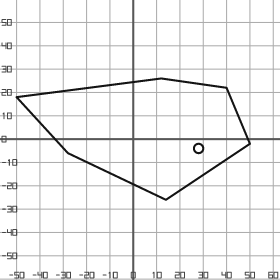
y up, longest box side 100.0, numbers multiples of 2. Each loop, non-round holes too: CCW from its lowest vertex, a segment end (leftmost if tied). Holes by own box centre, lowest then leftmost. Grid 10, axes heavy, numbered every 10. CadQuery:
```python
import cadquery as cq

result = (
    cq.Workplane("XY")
    .moveTo(14.0, -26.0)
    .lineTo(50.0, -2.0)
    .lineTo(40.0, 22.0)
    .lineTo(12.0, 26.0)
    .lineTo(-50.0, 18.0)
    .lineTo(-28.0, -6.0)
    .close()
    .moveTo(28.0, -4.0)
    .circle(2.0)
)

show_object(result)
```